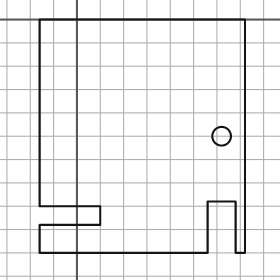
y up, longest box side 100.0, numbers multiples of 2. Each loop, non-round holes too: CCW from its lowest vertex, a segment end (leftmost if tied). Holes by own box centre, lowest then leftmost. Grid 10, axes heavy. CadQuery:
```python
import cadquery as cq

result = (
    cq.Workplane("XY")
    .moveTo(-16.0, -100.0)
    .lineTo(56.0, -100.0)
    .lineTo(56.0, -78.0)
    .lineTo(68.0, -78.0)
    .lineTo(68.0, -100.0)
    .lineTo(72.0, -100.0)
    .lineTo(72.0, 0.0)
    .lineTo(-16.0, 0.0)
    .lineTo(-16.0, -80.0)
    .lineTo(10.0, -80.0)
    .lineTo(10.0, -88.0)
    .lineTo(-16.0, -88.0)
    .close()
    .moveTo(62.0, -50.0)
    .circle(4.0)
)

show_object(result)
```